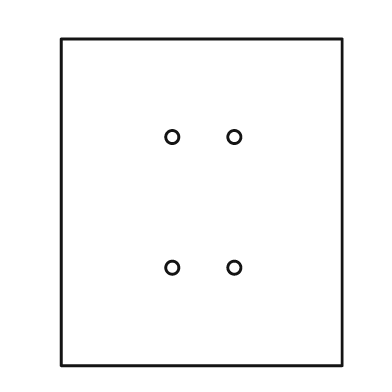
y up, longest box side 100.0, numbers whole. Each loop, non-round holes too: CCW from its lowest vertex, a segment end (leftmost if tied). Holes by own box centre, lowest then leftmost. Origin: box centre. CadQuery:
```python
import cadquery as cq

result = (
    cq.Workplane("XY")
    .moveTo(-43.0, -50.0)
    .lineTo(43.0, -50.0)
    .lineTo(43.0, 50.0)
    .lineTo(-43.0, 50.0)
    .close()
    .moveTo(-9.0, -20.0)
    .circle(2.0)
    .moveTo(10.0, -20.0)
    .circle(2.0)
    .moveTo(-9.0, 20.0)
    .circle(2.0)
    .moveTo(10.0, 20.0)
    .circle(2.0)
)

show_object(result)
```